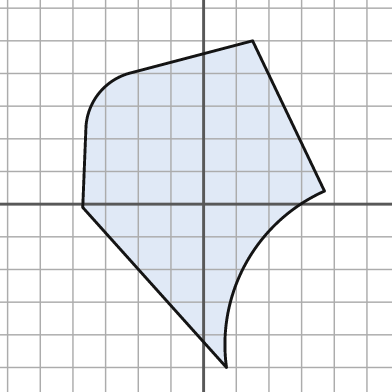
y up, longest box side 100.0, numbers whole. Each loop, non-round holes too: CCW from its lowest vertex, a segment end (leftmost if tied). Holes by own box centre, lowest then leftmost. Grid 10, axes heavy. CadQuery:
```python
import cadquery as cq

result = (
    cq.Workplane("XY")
    .moveTo(7.0, -50.0)
    .threePointArc((13.0, -18.0), (37.0, 4.0))
    .lineTo(15.0, 50.0)
    .lineTo(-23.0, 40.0)
    .threePointArc((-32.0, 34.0), (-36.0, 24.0))
    .lineTo(-37.0, -1.0)
    .close()
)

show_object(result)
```